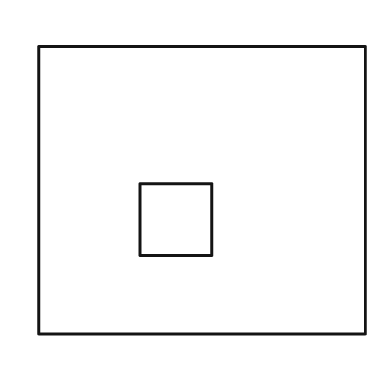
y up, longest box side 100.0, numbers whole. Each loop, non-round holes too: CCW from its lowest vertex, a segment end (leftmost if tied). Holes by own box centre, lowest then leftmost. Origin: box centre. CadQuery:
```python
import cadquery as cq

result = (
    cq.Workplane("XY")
    .moveTo(-50.0, -44.0)
    .lineTo(50.0, -44.0)
    .lineTo(50.0, 44.0)
    .lineTo(-50.0, 44.0)
    .close()
    .moveTo(-19.0, -20.0)
    .lineTo(3.0, -20.0)
    .lineTo(3.0, 2.0)
    .lineTo(-19.0, 2.0)
    .close()
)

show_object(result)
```